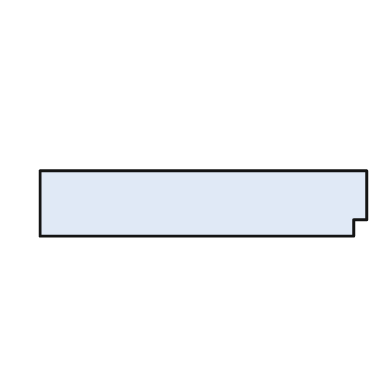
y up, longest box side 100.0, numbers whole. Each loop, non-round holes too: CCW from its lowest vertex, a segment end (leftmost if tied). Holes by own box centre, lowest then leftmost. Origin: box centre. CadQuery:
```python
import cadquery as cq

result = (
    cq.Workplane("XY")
    .moveTo(-50.0, -10.0)
    .lineTo(46.0, -10.0)
    .lineTo(46.0, -5.0)
    .lineTo(50.0, -5.0)
    .lineTo(50.0, 10.0)
    .lineTo(-50.0, 10.0)
    .close()
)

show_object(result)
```